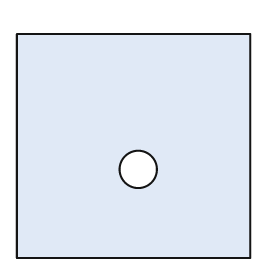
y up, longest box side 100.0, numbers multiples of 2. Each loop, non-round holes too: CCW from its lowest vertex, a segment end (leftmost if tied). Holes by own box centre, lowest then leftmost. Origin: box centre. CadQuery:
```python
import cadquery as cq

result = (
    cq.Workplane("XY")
    .moveTo(-50.0, -48.0)
    .lineTo(50.0, -48.0)
    .lineTo(50.0, 48.0)
    .lineTo(-50.0, 48.0)
    .close()
    .moveTo(2.0, -10.0)
    .circle(8.0)
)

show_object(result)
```